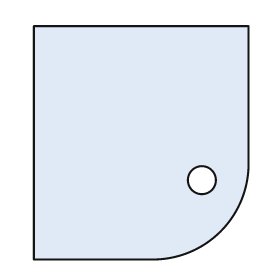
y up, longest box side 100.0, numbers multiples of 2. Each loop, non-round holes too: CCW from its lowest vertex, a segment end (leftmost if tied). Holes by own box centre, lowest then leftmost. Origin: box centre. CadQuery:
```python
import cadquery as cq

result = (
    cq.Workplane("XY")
    .moveTo(-46.0, -50.0)
    .lineTo(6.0, -50.0)
    .threePointArc((34.0, -38.0), (46.0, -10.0))
    .lineTo(46.0, 50.0)
    .lineTo(-46.0, 50.0)
    .close()
    .moveTo(26.0, -16.0)
    .circle(6.0)
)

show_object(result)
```